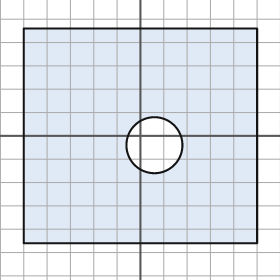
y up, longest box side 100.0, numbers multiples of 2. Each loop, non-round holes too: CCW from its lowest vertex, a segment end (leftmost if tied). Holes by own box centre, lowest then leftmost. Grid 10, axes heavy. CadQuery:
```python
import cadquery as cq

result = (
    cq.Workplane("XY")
    .moveTo(-50.0, -46.0)
    .lineTo(50.0, -46.0)
    .lineTo(50.0, 46.0)
    .lineTo(-50.0, 46.0)
    .close()
    .moveTo(6.0, -4.0)
    .circle(12.0)
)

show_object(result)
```